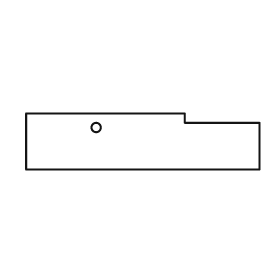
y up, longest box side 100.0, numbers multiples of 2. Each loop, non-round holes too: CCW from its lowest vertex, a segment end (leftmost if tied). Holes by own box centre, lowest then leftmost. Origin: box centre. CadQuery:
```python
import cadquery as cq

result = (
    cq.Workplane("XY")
    .moveTo(-50.0, -12.0)
    .lineTo(50.0, -12.0)
    .lineTo(50.0, 8.0)
    .lineTo(18.0, 8.0)
    .lineTo(18.0, 12.0)
    .lineTo(-50.0, 12.0)
    .close()
    .moveTo(-20.0, 6.0)
    .circle(2.0)
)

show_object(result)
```